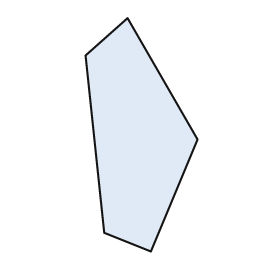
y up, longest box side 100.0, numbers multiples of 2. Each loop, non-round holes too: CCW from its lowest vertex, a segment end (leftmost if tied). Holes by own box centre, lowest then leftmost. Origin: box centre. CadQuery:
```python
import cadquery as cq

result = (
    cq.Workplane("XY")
    .moveTo(4.0, -50.0)
    .lineTo(24.0, -2.0)
    .lineTo(-6.0, 50.0)
    .lineTo(-24.0, 34.0)
    .lineTo(-16.0, -42.0)
    .close()
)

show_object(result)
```